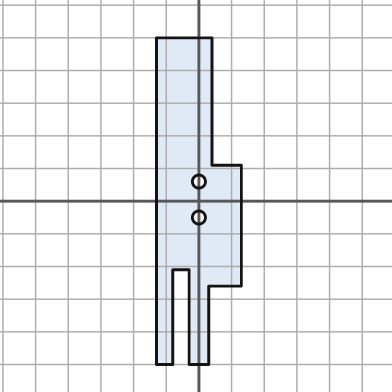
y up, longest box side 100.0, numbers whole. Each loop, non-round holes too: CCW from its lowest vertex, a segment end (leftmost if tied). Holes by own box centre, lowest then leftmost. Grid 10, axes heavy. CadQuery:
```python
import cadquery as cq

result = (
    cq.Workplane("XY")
    .moveTo(-13.0, -50.0)
    .lineTo(-8.0, -50.0)
    .lineTo(-8.0, -21.0)
    .lineTo(-3.0, -21.0)
    .lineTo(-3.0, -50.0)
    .lineTo(3.0, -50.0)
    .lineTo(3.0, -26.0)
    .lineTo(13.0, -26.0)
    .lineTo(13.0, 11.0)
    .lineTo(4.0, 11.0)
    .lineTo(4.0, 50.0)
    .lineTo(-13.0, 50.0)
    .close()
    .moveTo(0.0, -5.0)
    .circle(2.0)
    .moveTo(0.0, 6.0)
    .circle(2.0)
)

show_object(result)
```